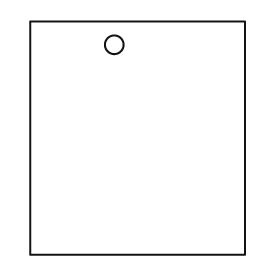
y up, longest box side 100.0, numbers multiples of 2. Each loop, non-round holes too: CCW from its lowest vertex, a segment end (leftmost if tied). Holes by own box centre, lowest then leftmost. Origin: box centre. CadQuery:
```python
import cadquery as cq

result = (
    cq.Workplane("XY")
    .moveTo(-46.0, -50.0)
    .lineTo(46.0, -50.0)
    .lineTo(46.0, 50.0)
    .lineTo(-46.0, 50.0)
    .close()
    .moveTo(-10.0, 40.0)
    .circle(4.0)
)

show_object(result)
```